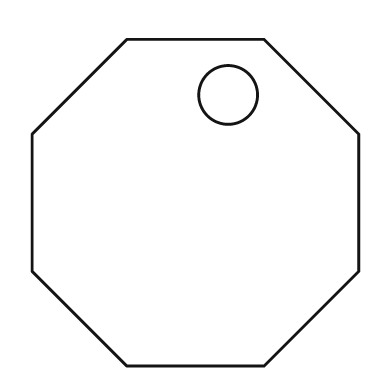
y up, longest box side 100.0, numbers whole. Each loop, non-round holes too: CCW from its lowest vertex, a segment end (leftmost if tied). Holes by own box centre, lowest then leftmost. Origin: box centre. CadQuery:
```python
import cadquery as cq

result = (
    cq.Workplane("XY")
    .moveTo(-21.0, -50.0)
    .lineTo(21.0, -50.0)
    .lineTo(50.0, -21.0)
    .lineTo(50.0, 21.0)
    .lineTo(21.0, 50.0)
    .lineTo(-21.0, 50.0)
    .lineTo(-50.0, 21.0)
    .lineTo(-50.0, -21.0)
    .close()
    .moveTo(10.0, 33.0)
    .circle(9.0)
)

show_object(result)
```